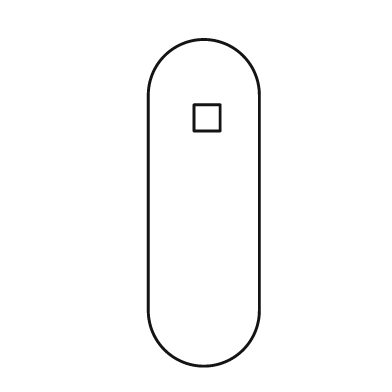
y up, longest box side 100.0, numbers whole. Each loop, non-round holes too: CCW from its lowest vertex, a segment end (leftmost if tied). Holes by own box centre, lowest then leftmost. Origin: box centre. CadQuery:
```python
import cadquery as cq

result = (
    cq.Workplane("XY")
    .moveTo(-17.0, -33.0)
    .threePointArc((0.0, -50.0), (17.0, -33.0))
    .lineTo(17.0, 33.0)
    .threePointArc((0.0, 50.0), (-17.0, 33.0))
    .close()
    .moveTo(-3.0, 22.0)
    .lineTo(5.0, 22.0)
    .lineTo(5.0, 30.0)
    .lineTo(-3.0, 30.0)
    .close()
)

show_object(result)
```